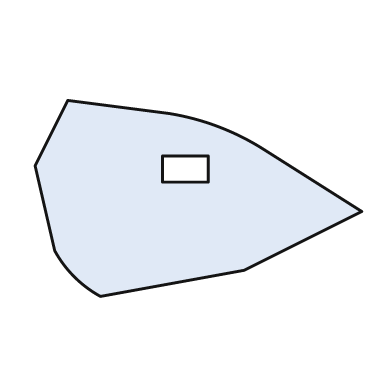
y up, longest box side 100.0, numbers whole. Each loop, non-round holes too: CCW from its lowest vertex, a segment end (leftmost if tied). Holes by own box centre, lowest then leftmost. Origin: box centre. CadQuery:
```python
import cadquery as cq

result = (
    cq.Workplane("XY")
    .moveTo(-30.0, -30.0)
    .lineTo(14.0, -22.0)
    .lineTo(50.0, -4.0)
    .lineTo(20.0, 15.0)
    .threePointArc((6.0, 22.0), (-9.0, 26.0))
    .lineTo(-40.0, 30.0)
    .lineTo(-50.0, 10.0)
    .lineTo(-44.0, -16.0)
    .threePointArc((-38.0, -24.0), (-30.0, -30.0))
    .close()
    .moveTo(-11.0, 5.0)
    .lineTo(3.0, 5.0)
    .lineTo(3.0, 13.0)
    .lineTo(-11.0, 13.0)
    .close()
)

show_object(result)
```